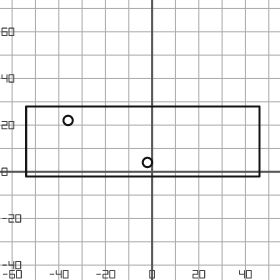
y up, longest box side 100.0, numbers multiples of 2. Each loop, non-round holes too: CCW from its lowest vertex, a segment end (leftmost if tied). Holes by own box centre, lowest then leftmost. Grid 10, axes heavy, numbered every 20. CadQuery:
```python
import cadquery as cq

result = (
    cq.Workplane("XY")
    .moveTo(-54.0, -2.0)
    .lineTo(46.0, -2.0)
    .lineTo(46.0, 28.0)
    .lineTo(-54.0, 28.0)
    .close()
    .moveTo(-2.0, 4.0)
    .circle(2.0)
    .moveTo(-36.0, 22.0)
    .circle(2.0)
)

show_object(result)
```